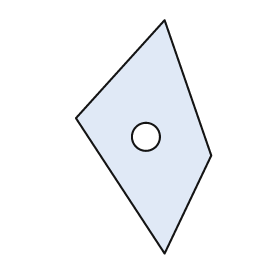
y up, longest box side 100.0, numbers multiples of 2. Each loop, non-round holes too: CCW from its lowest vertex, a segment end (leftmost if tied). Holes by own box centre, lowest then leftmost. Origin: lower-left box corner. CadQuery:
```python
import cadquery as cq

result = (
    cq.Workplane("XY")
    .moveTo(38.0, 0.0)
    .lineTo(58.0, 42.0)
    .lineTo(38.0, 100.0)
    .lineTo(0.0, 58.0)
    .close()
    .moveTo(30.0, 50.0)
    .circle(6.0)
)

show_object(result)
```